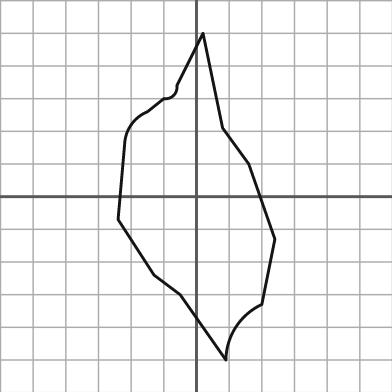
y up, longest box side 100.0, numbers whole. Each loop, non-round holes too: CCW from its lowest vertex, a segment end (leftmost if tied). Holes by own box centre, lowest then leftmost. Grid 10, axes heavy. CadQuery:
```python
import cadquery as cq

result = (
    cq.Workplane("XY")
    .moveTo(9.0, -50.0)
    .threePointArc((12.0, -40.0), (20.0, -33.0))
    .lineTo(24.0, -13.0)
    .lineTo(16.0, 10.0)
    .lineTo(8.0, 21.0)
    .lineTo(2.0, 50.0)
    .lineTo(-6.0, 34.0)
    .threePointArc((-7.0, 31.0), (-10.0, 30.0))
    .lineTo(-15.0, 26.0)
    .threePointArc((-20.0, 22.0), (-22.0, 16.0))
    .lineTo(-24.0, -7.0)
    .lineTo(-13.0, -24.0)
    .lineTo(-5.0, -30.0)
    .close()
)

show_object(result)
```